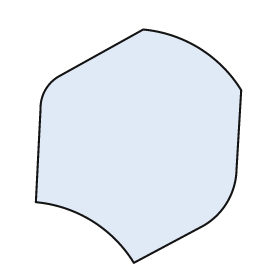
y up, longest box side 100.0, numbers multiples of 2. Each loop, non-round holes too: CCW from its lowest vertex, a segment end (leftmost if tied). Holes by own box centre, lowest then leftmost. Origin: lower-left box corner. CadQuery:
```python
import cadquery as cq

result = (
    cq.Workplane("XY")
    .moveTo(42.0, 0.0)
    .lineTo(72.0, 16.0)
    .threePointArc((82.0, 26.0), (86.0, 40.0))
    .lineTo(88.0, 74.0)
    .threePointArc((70.0, 92.0), (46.0, 100.0))
    .lineTo(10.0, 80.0)
    .threePointArc((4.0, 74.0), (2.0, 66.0))
    .lineTo(0.0, 26.0)
    .threePointArc((24.0, 18.0), (42.0, 0.0))
    .close()
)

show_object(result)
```